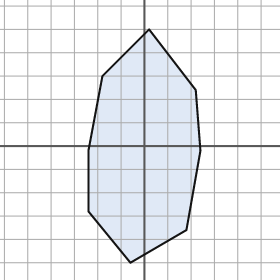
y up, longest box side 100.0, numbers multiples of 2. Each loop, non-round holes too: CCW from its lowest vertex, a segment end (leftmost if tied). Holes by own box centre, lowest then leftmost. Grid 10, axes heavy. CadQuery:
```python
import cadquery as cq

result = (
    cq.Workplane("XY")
    .moveTo(-6.0, -50.0)
    .lineTo(18.0, -36.0)
    .lineTo(24.0, -2.0)
    .lineTo(22.0, 24.0)
    .lineTo(2.0, 50.0)
    .lineTo(-18.0, 30.0)
    .lineTo(-24.0, -2.0)
    .lineTo(-24.0, -28.0)
    .close()
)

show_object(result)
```